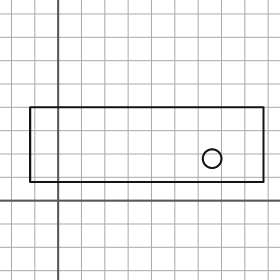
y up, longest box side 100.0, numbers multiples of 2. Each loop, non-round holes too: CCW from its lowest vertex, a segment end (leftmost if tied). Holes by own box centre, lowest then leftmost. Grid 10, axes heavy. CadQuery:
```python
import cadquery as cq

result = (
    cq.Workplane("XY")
    .moveTo(-12.0, 8.0)
    .lineTo(88.0, 8.0)
    .lineTo(88.0, 40.0)
    .lineTo(-12.0, 40.0)
    .close()
    .moveTo(66.0, 18.0)
    .circle(4.0)
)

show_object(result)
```